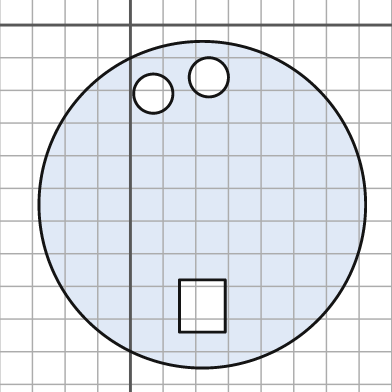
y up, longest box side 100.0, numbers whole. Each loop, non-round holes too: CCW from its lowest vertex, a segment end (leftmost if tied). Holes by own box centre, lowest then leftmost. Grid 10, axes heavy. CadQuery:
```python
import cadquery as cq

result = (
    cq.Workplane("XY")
    .moveTo(22.0, -55.0)
    .circle(50.0)
    .moveTo(15.0, -94.0)
    .lineTo(29.0, -94.0)
    .lineTo(29.0, -78.0)
    .lineTo(15.0, -78.0)
    .close()
    .moveTo(7.0, -21.0)
    .circle(6.0)
    .moveTo(24.0, -16.0)
    .circle(6.0)
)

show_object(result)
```